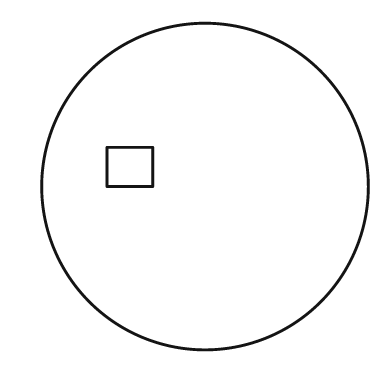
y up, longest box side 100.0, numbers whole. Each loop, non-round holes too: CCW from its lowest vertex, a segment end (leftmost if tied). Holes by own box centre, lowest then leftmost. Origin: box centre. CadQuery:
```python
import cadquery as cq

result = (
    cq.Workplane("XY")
    .moveTo(0.0, 0.0)
    .circle(50.0)
    .moveTo(-30.0, 0.0)
    .lineTo(-16.0, 0.0)
    .lineTo(-16.0, 12.0)
    .lineTo(-30.0, 12.0)
    .close()
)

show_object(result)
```